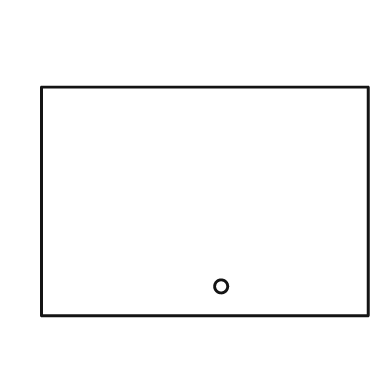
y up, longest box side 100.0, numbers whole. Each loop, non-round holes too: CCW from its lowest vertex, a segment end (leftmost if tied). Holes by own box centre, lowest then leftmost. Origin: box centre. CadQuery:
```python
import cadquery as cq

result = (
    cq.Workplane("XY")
    .moveTo(-50.0, -35.0)
    .lineTo(50.0, -35.0)
    .lineTo(50.0, 35.0)
    .lineTo(-50.0, 35.0)
    .close()
    .moveTo(5.0, -26.0)
    .circle(2.0)
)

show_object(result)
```